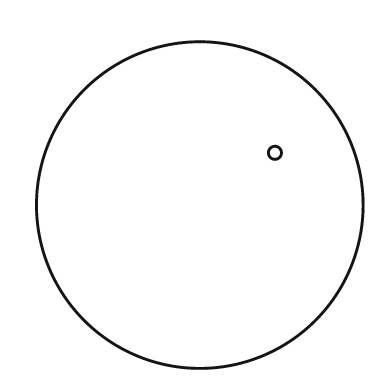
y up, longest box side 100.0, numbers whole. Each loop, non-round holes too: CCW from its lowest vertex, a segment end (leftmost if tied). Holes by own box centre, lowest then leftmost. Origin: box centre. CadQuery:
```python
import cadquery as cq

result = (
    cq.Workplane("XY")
    .moveTo(0.0, 0.0)
    .circle(50.0)
    .moveTo(23.0, 16.0)
    .circle(2.0)
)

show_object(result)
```